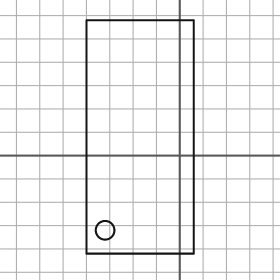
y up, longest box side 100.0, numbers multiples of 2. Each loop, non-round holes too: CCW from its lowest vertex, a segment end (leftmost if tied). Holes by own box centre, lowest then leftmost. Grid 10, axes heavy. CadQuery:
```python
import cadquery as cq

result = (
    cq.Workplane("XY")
    .moveTo(-40.0, -42.0)
    .lineTo(6.0, -42.0)
    .lineTo(6.0, 58.0)
    .lineTo(-40.0, 58.0)
    .close()
    .moveTo(-32.0, -32.0)
    .circle(4.0)
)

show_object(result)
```